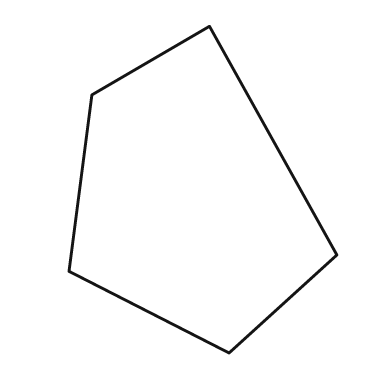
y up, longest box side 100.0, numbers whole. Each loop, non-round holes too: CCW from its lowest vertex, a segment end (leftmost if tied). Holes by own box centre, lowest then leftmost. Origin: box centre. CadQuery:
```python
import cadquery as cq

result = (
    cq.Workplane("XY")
    .moveTo(8.0, -50.0)
    .lineTo(41.0, -20.0)
    .lineTo(2.0, 50.0)
    .lineTo(-34.0, 29.0)
    .lineTo(-41.0, -25.0)
    .close()
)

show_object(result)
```